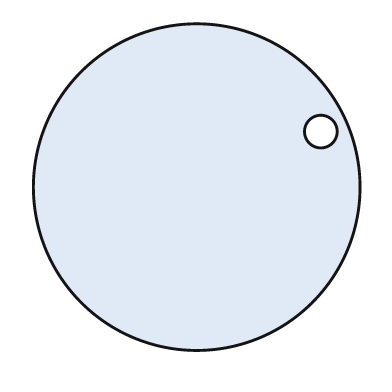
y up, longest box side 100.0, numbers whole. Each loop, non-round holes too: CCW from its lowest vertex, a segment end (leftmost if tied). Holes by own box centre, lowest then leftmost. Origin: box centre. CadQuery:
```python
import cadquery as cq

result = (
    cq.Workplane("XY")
    .moveTo(0.0, 0.0)
    .circle(50.0)
    .moveTo(38.0, 17.0)
    .circle(5.0)
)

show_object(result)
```